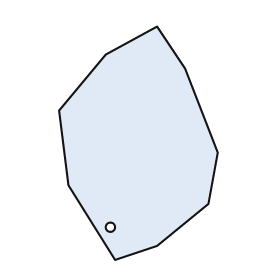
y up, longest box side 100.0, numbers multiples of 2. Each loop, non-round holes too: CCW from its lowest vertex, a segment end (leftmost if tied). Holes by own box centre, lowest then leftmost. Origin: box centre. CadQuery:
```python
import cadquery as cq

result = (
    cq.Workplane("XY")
    .moveTo(-10.0, -50.0)
    .lineTo(8.0, -44.0)
    .lineTo(30.0, -26.0)
    .lineTo(34.0, -4.0)
    .lineTo(20.0, 32.0)
    .lineTo(8.0, 50.0)
    .lineTo(-14.0, 38.0)
    .lineTo(-34.0, 14.0)
    .lineTo(-30.0, -18.0)
    .close()
    .moveTo(-12.0, -36.0)
    .circle(2.0)
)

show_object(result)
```